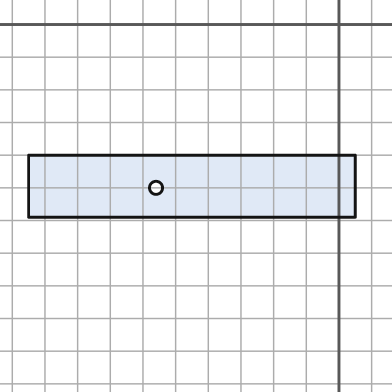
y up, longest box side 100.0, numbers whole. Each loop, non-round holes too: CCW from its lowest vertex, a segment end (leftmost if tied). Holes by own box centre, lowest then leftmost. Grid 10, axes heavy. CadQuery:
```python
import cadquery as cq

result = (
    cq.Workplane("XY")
    .moveTo(-95.0, -59.0)
    .lineTo(5.0, -59.0)
    .lineTo(5.0, -40.0)
    .lineTo(-95.0, -40.0)
    .close()
    .moveTo(-56.0, -50.0)
    .circle(2.0)
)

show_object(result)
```